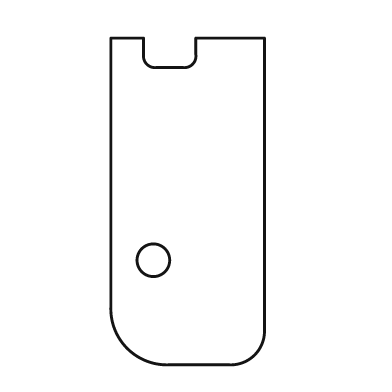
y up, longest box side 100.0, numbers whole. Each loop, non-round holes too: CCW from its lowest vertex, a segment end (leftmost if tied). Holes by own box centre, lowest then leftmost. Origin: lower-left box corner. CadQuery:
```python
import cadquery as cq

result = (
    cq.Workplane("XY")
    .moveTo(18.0, 0.0)
    .lineTo(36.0, 0.0)
    .threePointArc((44.0, 3.0), (47.0, 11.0))
    .lineTo(47.0, 100.0)
    .lineTo(26.0, 100.0)
    .lineTo(26.0, 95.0)
    .threePointArc((25.0, 92.0), (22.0, 91.0))
    .lineTo(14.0, 91.0)
    .threePointArc((11.0, 92.0), (10.0, 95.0))
    .lineTo(10.0, 100.0)
    .lineTo(0.0, 100.0)
    .lineTo(0.0, 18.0)
    .threePointArc((5.0, 5.0), (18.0, 0.0))
    .close()
    .moveTo(13.0, 32.0)
    .circle(5.0)
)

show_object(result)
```